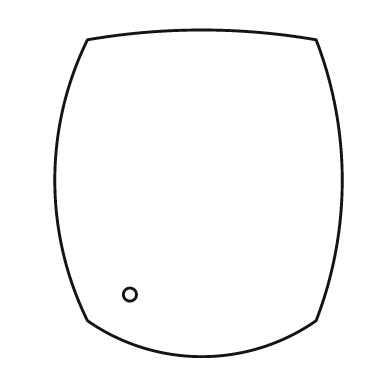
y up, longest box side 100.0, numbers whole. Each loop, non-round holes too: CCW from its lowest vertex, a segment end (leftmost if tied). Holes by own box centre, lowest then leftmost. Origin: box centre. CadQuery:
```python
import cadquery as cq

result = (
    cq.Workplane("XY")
    .moveTo(-34.0, -39.0)
    .threePointArc((1.0, -50.0), (36.0, -39.0))
    .threePointArc((44.0, 4.0), (36.0, 47.0))
    .threePointArc((1.0, 50.0), (-34.0, 47.0))
    .threePointArc((-44.0, 4.0), (-34.0, -39.0))
    .close()
    .moveTo(-21.0, -31.0)
    .circle(2.0)
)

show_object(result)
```